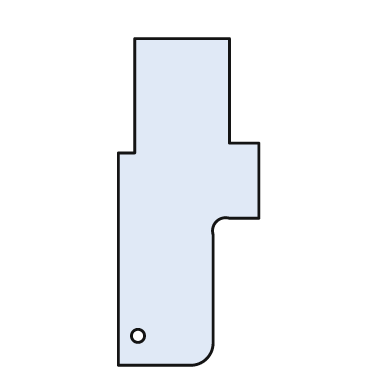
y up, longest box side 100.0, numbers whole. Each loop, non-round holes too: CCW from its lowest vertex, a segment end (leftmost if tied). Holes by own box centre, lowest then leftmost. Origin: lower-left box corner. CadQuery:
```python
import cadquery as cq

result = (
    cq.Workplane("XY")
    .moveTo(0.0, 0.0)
    .lineTo(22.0, 0.0)
    .threePointArc((27.0, 2.0), (29.0, 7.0))
    .lineTo(29.0, 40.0)
    .threePointArc((30.0, 44.0), (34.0, 45.0))
    .lineTo(43.0, 45.0)
    .lineTo(43.0, 68.0)
    .lineTo(34.0, 68.0)
    .lineTo(34.0, 100.0)
    .lineTo(5.0, 100.0)
    .lineTo(5.0, 65.0)
    .lineTo(0.0, 65.0)
    .close()
    .moveTo(6.0, 9.0)
    .circle(2.0)
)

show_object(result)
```